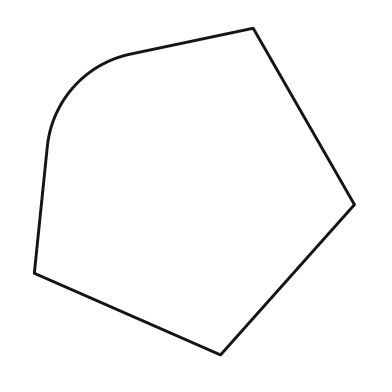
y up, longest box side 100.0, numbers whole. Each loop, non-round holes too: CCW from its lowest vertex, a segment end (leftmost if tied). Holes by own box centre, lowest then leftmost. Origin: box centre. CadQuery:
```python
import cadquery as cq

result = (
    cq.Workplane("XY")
    .moveTo(8.0, -50.0)
    .lineTo(49.0, -4.0)
    .lineTo(18.0, 50.0)
    .lineTo(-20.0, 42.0)
    .threePointArc((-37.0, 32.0), (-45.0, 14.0))
    .lineTo(-49.0, -25.0)
    .close()
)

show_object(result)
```